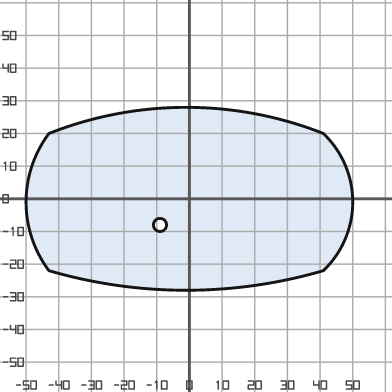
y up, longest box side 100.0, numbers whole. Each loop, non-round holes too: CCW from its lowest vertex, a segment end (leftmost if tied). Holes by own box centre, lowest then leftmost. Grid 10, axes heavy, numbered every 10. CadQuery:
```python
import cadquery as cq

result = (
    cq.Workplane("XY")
    .moveTo(-43.0, -22.0)
    .threePointArc((-1.0, -28.0), (41.0, -22.0))
    .threePointArc((50.0, -1.0), (41.0, 20.0))
    .threePointArc((-1.0, 28.0), (-43.0, 20.0))
    .threePointArc((-50.0, -1.0), (-43.0, -22.0))
    .close()
    .moveTo(-9.0, -8.0)
    .circle(2.0)
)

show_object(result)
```